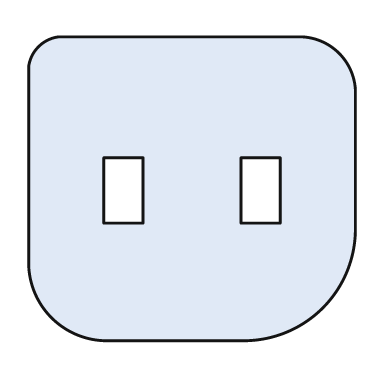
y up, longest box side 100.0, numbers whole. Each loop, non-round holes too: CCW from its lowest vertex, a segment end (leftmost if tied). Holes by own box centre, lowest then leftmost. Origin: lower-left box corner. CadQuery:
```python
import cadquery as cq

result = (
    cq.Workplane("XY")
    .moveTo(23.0, 0.0)
    .lineTo(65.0, 0.0)
    .threePointArc((90.0, 10.0), (100.0, 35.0))
    .lineTo(100.0, 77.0)
    .threePointArc((95.0, 88.0), (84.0, 93.0))
    .lineTo(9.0, 93.0)
    .threePointArc((3.0, 90.0), (0.0, 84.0))
    .lineTo(0.0, 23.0)
    .threePointArc((7.0, 7.0), (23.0, 0.0))
    .close()
    .moveTo(23.0, 36.0)
    .lineTo(35.0, 36.0)
    .lineTo(35.0, 56.0)
    .lineTo(23.0, 56.0)
    .close()
    .moveTo(65.0, 36.0)
    .lineTo(77.0, 36.0)
    .lineTo(77.0, 56.0)
    .lineTo(65.0, 56.0)
    .close()
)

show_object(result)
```